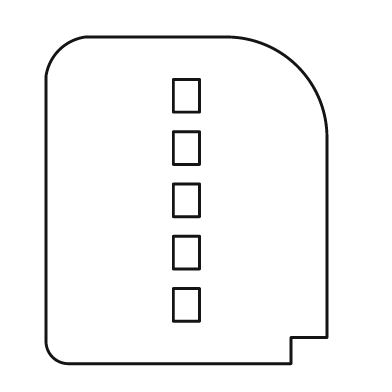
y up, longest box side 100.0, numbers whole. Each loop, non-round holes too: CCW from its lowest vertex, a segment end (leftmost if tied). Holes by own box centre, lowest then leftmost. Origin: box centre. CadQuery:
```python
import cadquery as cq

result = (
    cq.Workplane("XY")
    .moveTo(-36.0, -50.0)
    .lineTo(32.0, -50.0)
    .lineTo(32.0, -42.0)
    .lineTo(43.0, -42.0)
    .lineTo(43.0, 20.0)
    .threePointArc((34.0, 41.0), (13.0, 50.0))
    .lineTo(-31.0, 50.0)
    .threePointArc((-39.0, 46.0), (-43.0, 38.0))
    .lineTo(-43.0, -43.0)
    .threePointArc((-41.0, -48.0), (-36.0, -50.0))
    .close()
    .moveTo(-4.0, -37.0)
    .lineTo(4.0, -37.0)
    .lineTo(4.0, -27.0)
    .lineTo(-4.0, -27.0)
    .close()
    .moveTo(-4.0, -21.0)
    .lineTo(4.0, -21.0)
    .lineTo(4.0, -11.0)
    .lineTo(-4.0, -11.0)
    .close()
    .moveTo(-4.0, -5.0)
    .lineTo(4.0, -5.0)
    .lineTo(4.0, 5.0)
    .lineTo(-4.0, 5.0)
    .close()
    .moveTo(-4.0, 11.0)
    .lineTo(4.0, 11.0)
    .lineTo(4.0, 21.0)
    .lineTo(-4.0, 21.0)
    .close()
    .moveTo(-4.0, 27.0)
    .lineTo(4.0, 27.0)
    .lineTo(4.0, 37.0)
    .lineTo(-4.0, 37.0)
    .close()
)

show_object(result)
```